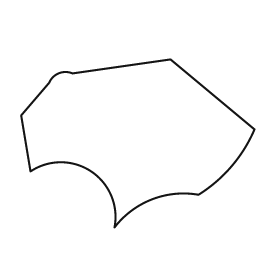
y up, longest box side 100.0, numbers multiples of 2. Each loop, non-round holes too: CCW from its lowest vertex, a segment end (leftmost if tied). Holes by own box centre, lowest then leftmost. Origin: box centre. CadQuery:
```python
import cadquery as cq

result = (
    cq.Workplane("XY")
    .moveTo(-10.0, -36.0)
    .threePointArc((6.0, -24.0), (26.0, -22.0))
    .threePointArc((40.0, -10.0), (50.0, 6.0))
    .lineTo(14.0, 36.0)
    .lineTo(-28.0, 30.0)
    .threePointArc((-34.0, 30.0), (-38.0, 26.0))
    .lineTo(-50.0, 12.0)
    .lineTo(-46.0, -12.0)
    .threePointArc((-20.0, -12.0), (-10.0, -36.0))
    .close()
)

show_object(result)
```